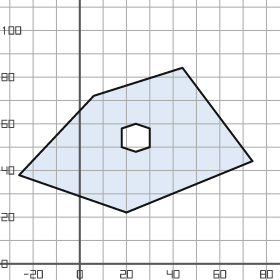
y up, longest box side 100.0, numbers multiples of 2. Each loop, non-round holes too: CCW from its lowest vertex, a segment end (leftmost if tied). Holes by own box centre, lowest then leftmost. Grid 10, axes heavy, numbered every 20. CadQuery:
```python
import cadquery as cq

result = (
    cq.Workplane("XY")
    .moveTo(20.0, 22.0)
    .lineTo(74.0, 44.0)
    .lineTo(44.0, 84.0)
    .lineTo(6.0, 72.0)
    .lineTo(-26.0, 38.0)
    .close()
    .moveTo(24.0, 48.0)
    .lineTo(30.0, 50.0)
    .lineTo(30.0, 58.0)
    .lineTo(24.0, 60.0)
    .lineTo(18.0, 58.0)
    .lineTo(18.0, 50.0)
    .close()
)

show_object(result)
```